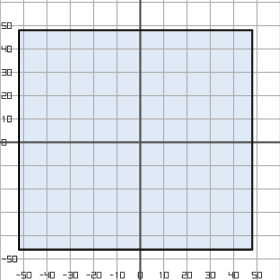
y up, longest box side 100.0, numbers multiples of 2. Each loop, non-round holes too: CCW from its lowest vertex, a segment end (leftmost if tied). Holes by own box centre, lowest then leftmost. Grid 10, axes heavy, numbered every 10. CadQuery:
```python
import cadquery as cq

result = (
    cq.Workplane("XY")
    .moveTo(-52.0, -46.0)
    .lineTo(48.0, -46.0)
    .lineTo(48.0, 48.0)
    .lineTo(-52.0, 48.0)
    .close()
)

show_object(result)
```